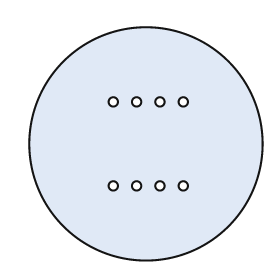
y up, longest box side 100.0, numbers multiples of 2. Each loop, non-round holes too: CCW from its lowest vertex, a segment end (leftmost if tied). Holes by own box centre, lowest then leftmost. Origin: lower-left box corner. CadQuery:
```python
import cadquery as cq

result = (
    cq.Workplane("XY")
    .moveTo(50.0, 50.0)
    .circle(50.0)
    .moveTo(36.0, 32.0)
    .circle(2.0)
    .moveTo(46.0, 32.0)
    .circle(2.0)
    .moveTo(56.0, 32.0)
    .circle(2.0)
    .moveTo(66.0, 32.0)
    .circle(2.0)
    .moveTo(36.0, 68.0)
    .circle(2.0)
    .moveTo(46.0, 68.0)
    .circle(2.0)
    .moveTo(56.0, 68.0)
    .circle(2.0)
    .moveTo(66.0, 68.0)
    .circle(2.0)
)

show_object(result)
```